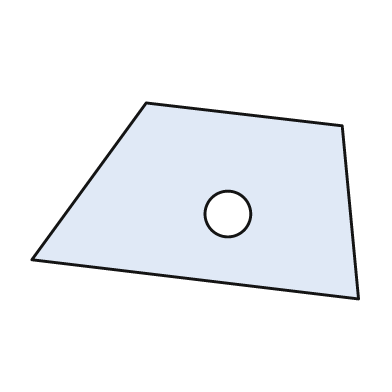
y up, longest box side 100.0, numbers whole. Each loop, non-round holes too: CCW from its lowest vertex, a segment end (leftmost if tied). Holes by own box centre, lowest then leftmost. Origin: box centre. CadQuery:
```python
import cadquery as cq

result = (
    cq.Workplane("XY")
    .moveTo(50.0, -30.0)
    .lineTo(45.0, 23.0)
    .lineTo(-15.0, 30.0)
    .lineTo(-50.0, -18.0)
    .close()
    .moveTo(10.0, -4.0)
    .circle(7.0)
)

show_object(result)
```